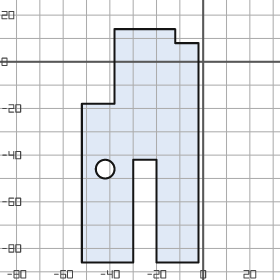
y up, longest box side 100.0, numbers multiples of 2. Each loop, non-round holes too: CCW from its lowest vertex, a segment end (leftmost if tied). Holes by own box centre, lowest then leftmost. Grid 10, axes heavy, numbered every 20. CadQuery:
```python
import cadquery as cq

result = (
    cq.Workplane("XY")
    .moveTo(-52.0, -86.0)
    .lineTo(-30.0, -86.0)
    .lineTo(-30.0, -42.0)
    .lineTo(-20.0, -42.0)
    .lineTo(-20.0, -86.0)
    .lineTo(-2.0, -86.0)
    .lineTo(-2.0, 8.0)
    .lineTo(-12.0, 8.0)
    .lineTo(-12.0, 14.0)
    .lineTo(-38.0, 14.0)
    .lineTo(-38.0, -18.0)
    .lineTo(-52.0, -18.0)
    .close()
    .moveTo(-42.0, -46.0)
    .circle(4.0)
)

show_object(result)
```